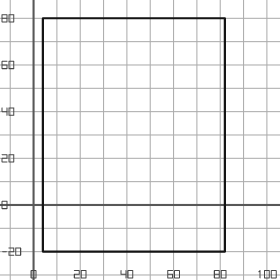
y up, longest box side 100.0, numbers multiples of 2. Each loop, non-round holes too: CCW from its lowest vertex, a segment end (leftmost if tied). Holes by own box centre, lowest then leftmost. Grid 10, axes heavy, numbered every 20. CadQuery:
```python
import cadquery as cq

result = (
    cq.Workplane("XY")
    .moveTo(4.0, -20.0)
    .lineTo(82.0, -20.0)
    .lineTo(82.0, 80.0)
    .lineTo(4.0, 80.0)
    .close()
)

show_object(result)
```